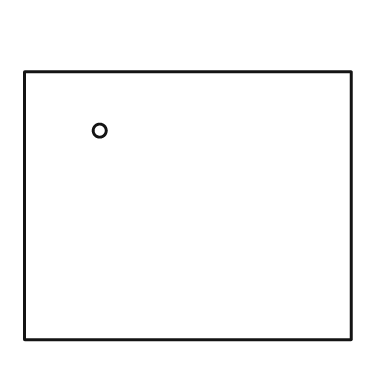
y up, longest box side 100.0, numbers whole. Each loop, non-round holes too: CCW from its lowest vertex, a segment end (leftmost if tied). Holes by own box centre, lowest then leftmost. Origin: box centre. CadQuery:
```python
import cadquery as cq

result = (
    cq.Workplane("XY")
    .moveTo(-50.0, -41.0)
    .lineTo(50.0, -41.0)
    .lineTo(50.0, 41.0)
    .lineTo(-50.0, 41.0)
    .close()
    .moveTo(-27.0, 23.0)
    .circle(2.0)
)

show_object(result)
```